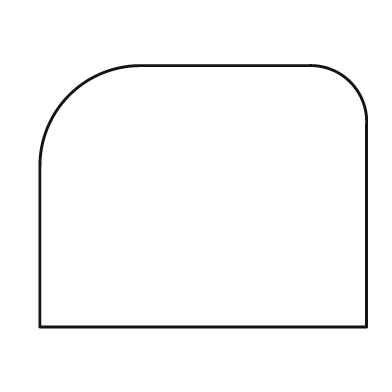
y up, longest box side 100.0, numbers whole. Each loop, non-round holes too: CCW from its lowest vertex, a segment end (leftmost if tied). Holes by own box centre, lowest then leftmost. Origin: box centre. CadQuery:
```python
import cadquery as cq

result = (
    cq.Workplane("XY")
    .moveTo(-50.0, -40.0)
    .lineTo(50.0, -40.0)
    .lineTo(50.0, 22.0)
    .threePointArc((45.0, 35.0), (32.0, 40.0))
    .lineTo(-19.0, 40.0)
    .threePointArc((-41.0, 31.0), (-50.0, 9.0))
    .close()
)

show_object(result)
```